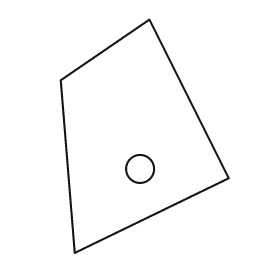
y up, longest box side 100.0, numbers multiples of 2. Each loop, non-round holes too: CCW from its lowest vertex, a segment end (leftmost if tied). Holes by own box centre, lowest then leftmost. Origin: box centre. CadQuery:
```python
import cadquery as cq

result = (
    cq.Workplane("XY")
    .moveTo(-30.0, -50.0)
    .lineTo(36.0, -18.0)
    .lineTo(2.0, 50.0)
    .lineTo(-36.0, 24.0)
    .close()
    .moveTo(-2.0, -14.0)
    .circle(6.0)
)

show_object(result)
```